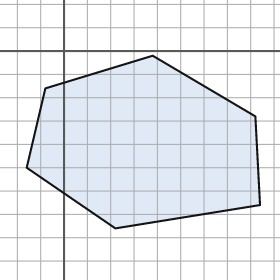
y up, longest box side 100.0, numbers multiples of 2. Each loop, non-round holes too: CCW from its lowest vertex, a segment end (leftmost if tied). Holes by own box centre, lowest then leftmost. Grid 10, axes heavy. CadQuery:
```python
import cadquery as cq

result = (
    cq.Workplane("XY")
    .moveTo(22.0, -76.0)
    .lineTo(84.0, -66.0)
    .lineTo(82.0, -28.0)
    .lineTo(38.0, -2.0)
    .lineTo(-8.0, -16.0)
    .lineTo(-16.0, -50.0)
    .close()
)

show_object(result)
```